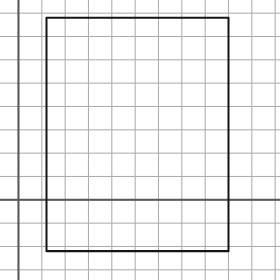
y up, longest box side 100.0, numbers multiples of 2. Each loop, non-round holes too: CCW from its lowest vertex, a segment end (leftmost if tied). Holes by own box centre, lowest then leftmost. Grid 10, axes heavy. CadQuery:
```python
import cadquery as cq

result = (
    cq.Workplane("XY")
    .moveTo(12.0, -22.0)
    .lineTo(90.0, -22.0)
    .lineTo(90.0, 78.0)
    .lineTo(12.0, 78.0)
    .close()
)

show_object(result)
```